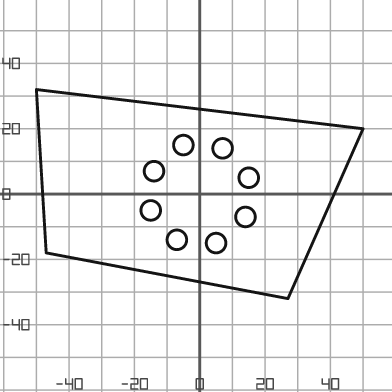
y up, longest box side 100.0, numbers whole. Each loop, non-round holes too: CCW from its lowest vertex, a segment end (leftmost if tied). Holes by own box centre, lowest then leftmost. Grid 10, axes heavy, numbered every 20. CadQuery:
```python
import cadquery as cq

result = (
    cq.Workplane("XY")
    .moveTo(27.0, -32.0)
    .lineTo(50.0, 20.0)
    .lineTo(-50.0, 32.0)
    .lineTo(-47.0, -18.0)
    .close()
    .moveTo(5.0, -15.0)
    .circle(3.0)
    .moveTo(-7.0, -14.0)
    .circle(3.0)
    .moveTo(14.0, -7.0)
    .circle(3.0)
    .moveTo(-15.0, -5.0)
    .circle(3.0)
    .moveTo(15.0, 5.0)
    .circle(3.0)
    .moveTo(-14.0, 7.0)
    .circle(3.0)
    .moveTo(7.0, 14.0)
    .circle(3.0)
    .moveTo(-5.0, 15.0)
    .circle(3.0)
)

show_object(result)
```